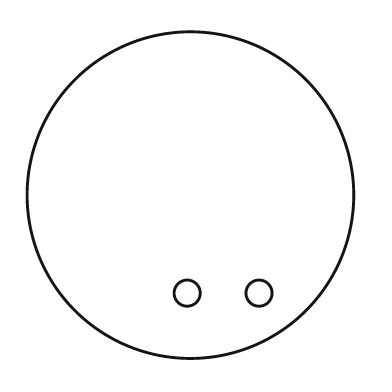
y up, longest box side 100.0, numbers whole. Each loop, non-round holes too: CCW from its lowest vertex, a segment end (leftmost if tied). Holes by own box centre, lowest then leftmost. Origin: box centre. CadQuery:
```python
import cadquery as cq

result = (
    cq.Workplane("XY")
    .moveTo(0.0, 0.0)
    .circle(50.0)
    .moveTo(-1.0, -30.0)
    .circle(4.0)
    .moveTo(21.0, -30.0)
    .circle(4.0)
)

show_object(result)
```